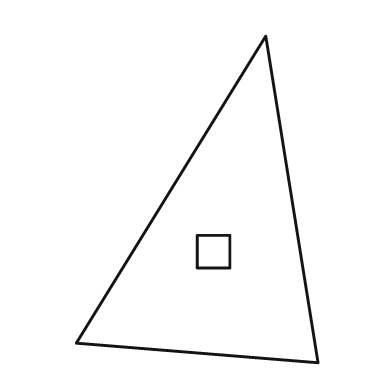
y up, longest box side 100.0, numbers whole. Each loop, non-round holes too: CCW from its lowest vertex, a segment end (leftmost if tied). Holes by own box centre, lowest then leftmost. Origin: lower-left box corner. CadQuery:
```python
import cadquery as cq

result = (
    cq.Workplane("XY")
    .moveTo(74.0, 0.0)
    .lineTo(58.0, 100.0)
    .lineTo(0.0, 6.0)
    .close()
    .moveTo(37.0, 29.0)
    .lineTo(47.0, 29.0)
    .lineTo(47.0, 39.0)
    .lineTo(37.0, 39.0)
    .close()
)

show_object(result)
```